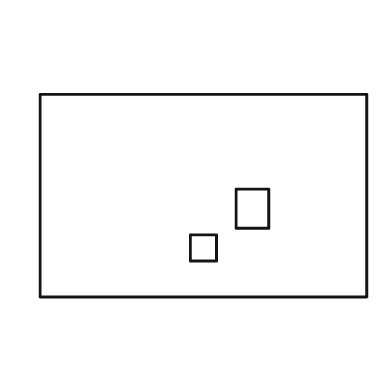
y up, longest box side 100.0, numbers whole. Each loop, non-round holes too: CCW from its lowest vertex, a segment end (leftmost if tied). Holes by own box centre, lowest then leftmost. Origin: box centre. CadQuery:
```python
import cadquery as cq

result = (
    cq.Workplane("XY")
    .moveTo(-50.0, -31.0)
    .lineTo(50.0, -31.0)
    .lineTo(50.0, 31.0)
    .lineTo(-50.0, 31.0)
    .close()
    .moveTo(-4.0, -20.0)
    .lineTo(4.0, -20.0)
    .lineTo(4.0, -12.0)
    .lineTo(-4.0, -12.0)
    .close()
    .moveTo(10.0, -10.0)
    .lineTo(20.0, -10.0)
    .lineTo(20.0, 2.0)
    .lineTo(10.0, 2.0)
    .close()
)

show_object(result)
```